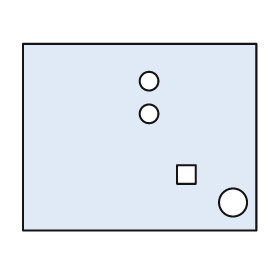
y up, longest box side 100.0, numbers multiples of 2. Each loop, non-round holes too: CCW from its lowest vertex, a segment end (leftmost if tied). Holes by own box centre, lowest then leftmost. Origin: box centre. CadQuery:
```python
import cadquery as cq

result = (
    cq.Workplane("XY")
    .moveTo(-50.0, -40.0)
    .lineTo(50.0, -40.0)
    .lineTo(50.0, 40.0)
    .lineTo(-50.0, 40.0)
    .close()
    .moveTo(40.0, -28.0)
    .circle(6.0)
    .moveTo(16.0, -20.0)
    .lineTo(24.0, -20.0)
    .lineTo(24.0, -12.0)
    .lineTo(16.0, -12.0)
    .close()
    .moveTo(4.0, 10.0)
    .circle(4.0)
    .moveTo(4.0, 24.0)
    .circle(4.0)
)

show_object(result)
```